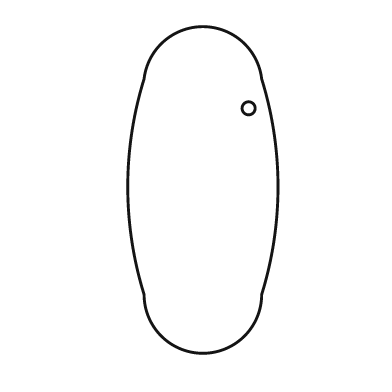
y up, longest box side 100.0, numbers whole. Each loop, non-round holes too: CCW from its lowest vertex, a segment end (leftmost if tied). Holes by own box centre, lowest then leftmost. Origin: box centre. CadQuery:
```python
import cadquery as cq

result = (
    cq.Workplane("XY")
    .moveTo(-18.0, -32.0)
    .threePointArc((0.0, -50.0), (18.0, -32.0))
    .threePointArc((23.0, 1.0), (18.0, 34.0))
    .threePointArc((0.0, 50.0), (-18.0, 34.0))
    .threePointArc((-23.0, 1.0), (-18.0, -32.0))
    .close()
    .moveTo(14.0, 25.0)
    .circle(2.0)
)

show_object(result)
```